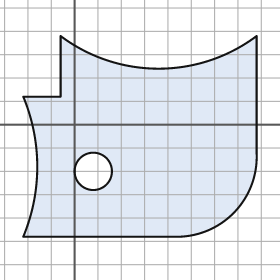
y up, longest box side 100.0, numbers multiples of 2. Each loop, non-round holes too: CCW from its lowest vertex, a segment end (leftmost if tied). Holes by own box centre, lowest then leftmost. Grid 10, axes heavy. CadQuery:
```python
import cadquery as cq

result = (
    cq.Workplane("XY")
    .moveTo(-22.0, -48.0)
    .lineTo(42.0, -48.0)
    .threePointArc((68.0, -38.0), (78.0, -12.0))
    .lineTo(78.0, 38.0)
    .threePointArc((36.0, 24.0), (-6.0, 38.0))
    .lineTo(-6.0, 12.0)
    .lineTo(-22.0, 12.0)
    .threePointArc((-16.0, -18.0), (-22.0, -48.0))
    .close()
    .moveTo(8.0, -20.0)
    .circle(8.0)
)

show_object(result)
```